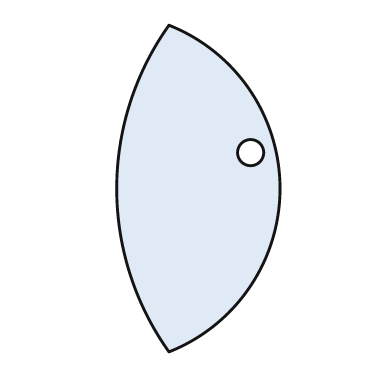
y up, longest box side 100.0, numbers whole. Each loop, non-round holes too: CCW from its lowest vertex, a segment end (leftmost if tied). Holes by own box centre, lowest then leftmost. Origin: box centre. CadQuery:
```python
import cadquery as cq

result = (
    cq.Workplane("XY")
    .moveTo(-9.0, -50.0)
    .threePointArc((25.0, 0.0), (-9.0, 50.0))
    .threePointArc((-25.0, 0.0), (-9.0, -50.0))
    .close()
    .moveTo(16.0, 11.0)
    .circle(4.0)
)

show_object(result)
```